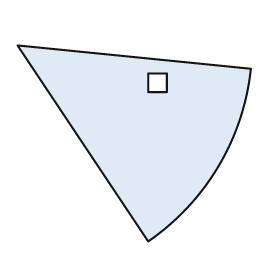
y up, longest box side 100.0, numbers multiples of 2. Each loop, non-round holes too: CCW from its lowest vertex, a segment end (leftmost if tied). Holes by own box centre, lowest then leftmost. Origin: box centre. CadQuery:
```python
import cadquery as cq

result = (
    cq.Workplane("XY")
    .moveTo(6.0, -42.0)
    .threePointArc((36.0, -10.0), (50.0, 32.0))
    .lineTo(-50.0, 42.0)
    .close()
    .moveTo(6.0, 22.0)
    .lineTo(14.0, 22.0)
    .lineTo(14.0, 30.0)
    .lineTo(6.0, 30.0)
    .close()
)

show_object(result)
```